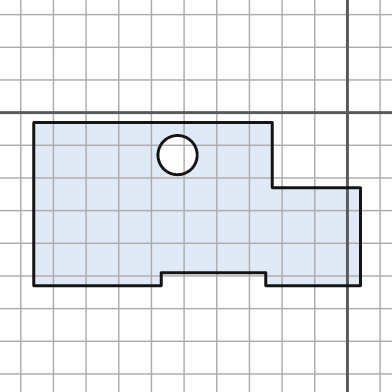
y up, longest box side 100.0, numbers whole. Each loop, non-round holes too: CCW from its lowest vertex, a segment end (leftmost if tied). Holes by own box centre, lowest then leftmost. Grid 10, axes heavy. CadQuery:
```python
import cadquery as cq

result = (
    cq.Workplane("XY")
    .moveTo(-96.0, -53.0)
    .lineTo(-57.0, -53.0)
    .lineTo(-57.0, -49.0)
    .lineTo(-25.0, -49.0)
    .lineTo(-25.0, -53.0)
    .lineTo(4.0, -53.0)
    .lineTo(4.0, -23.0)
    .lineTo(-23.0, -23.0)
    .lineTo(-23.0, -3.0)
    .lineTo(-96.0, -3.0)
    .close()
    .moveTo(-52.0, -13.0)
    .circle(6.0)
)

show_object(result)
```